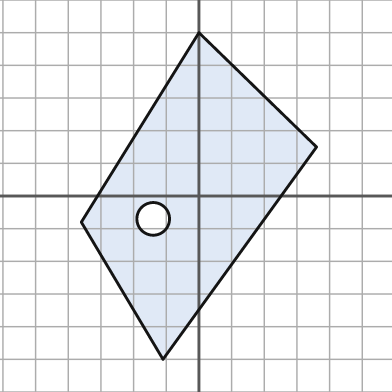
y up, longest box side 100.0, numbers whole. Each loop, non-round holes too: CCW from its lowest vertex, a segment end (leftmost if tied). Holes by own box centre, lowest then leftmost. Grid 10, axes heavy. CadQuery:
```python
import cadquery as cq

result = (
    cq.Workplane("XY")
    .moveTo(-11.0, -50.0)
    .lineTo(36.0, 15.0)
    .lineTo(0.0, 50.0)
    .lineTo(-36.0, -8.0)
    .close()
    .moveTo(-14.0, -7.0)
    .circle(5.0)
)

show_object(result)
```